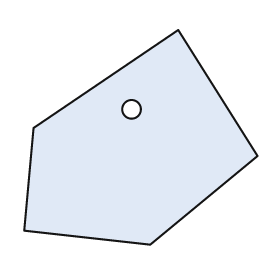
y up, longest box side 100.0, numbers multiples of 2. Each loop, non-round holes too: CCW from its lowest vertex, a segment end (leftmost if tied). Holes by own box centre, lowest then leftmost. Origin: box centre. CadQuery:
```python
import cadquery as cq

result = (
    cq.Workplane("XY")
    .moveTo(4.0, -46.0)
    .lineTo(50.0, -8.0)
    .lineTo(16.0, 46.0)
    .lineTo(-46.0, 4.0)
    .lineTo(-50.0, -40.0)
    .close()
    .moveTo(-4.0, 12.0)
    .circle(4.0)
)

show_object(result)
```